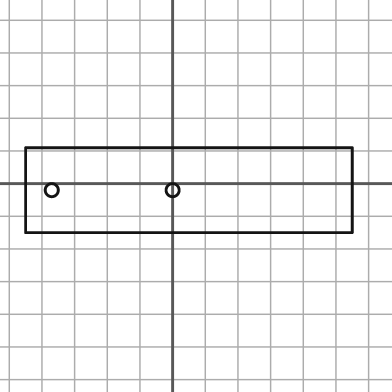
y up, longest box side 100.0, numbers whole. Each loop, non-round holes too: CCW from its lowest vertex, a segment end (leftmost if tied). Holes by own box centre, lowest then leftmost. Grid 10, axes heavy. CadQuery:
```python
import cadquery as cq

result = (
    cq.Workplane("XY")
    .moveTo(-45.0, -15.0)
    .lineTo(55.0, -15.0)
    .lineTo(55.0, 11.0)
    .lineTo(-45.0, 11.0)
    .close()
    .moveTo(-37.0, -2.0)
    .circle(2.0)
    .moveTo(0.0, -2.0)
    .circle(2.0)
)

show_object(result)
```